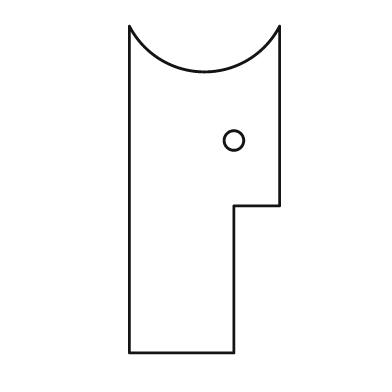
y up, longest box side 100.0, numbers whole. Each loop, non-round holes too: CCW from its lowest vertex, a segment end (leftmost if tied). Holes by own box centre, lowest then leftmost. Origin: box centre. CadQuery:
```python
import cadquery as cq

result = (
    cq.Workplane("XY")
    .moveTo(-23.0, -50.0)
    .lineTo(9.0, -50.0)
    .lineTo(9.0, -5.0)
    .lineTo(23.0, -5.0)
    .lineTo(23.0, 50.0)
    .threePointArc((0.0, 36.0), (-23.0, 50.0))
    .close()
    .moveTo(9.0, 15.0)
    .circle(3.0)
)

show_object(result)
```